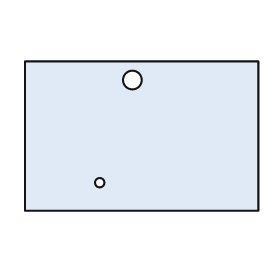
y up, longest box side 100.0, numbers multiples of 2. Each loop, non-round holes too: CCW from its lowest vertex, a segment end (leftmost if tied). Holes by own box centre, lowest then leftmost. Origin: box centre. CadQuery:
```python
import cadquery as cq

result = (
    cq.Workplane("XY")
    .moveTo(-50.0, -32.0)
    .lineTo(50.0, -32.0)
    .lineTo(50.0, 32.0)
    .lineTo(-50.0, 32.0)
    .close()
    .moveTo(-18.0, -20.0)
    .circle(2.0)
    .moveTo(-4.0, 24.0)
    .circle(4.0)
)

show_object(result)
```